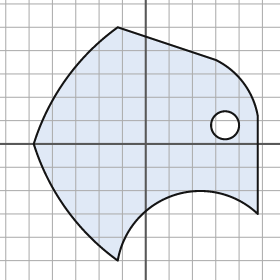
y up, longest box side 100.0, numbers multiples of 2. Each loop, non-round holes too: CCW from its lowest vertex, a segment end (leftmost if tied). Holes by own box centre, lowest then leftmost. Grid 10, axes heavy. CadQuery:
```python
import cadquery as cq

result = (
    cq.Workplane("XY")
    .moveTo(-12.0, -50.0)
    .threePointArc((12.0, -22.0), (48.0, -30.0))
    .lineTo(48.0, 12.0)
    .threePointArc((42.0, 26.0), (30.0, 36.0))
    .lineTo(-12.0, 50.0)
    .threePointArc((-34.0, 28.0), (-48.0, 0.0))
    .threePointArc((-34.0, -28.0), (-12.0, -50.0))
    .close()
    .moveTo(34.0, 8.0)
    .circle(6.0)
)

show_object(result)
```